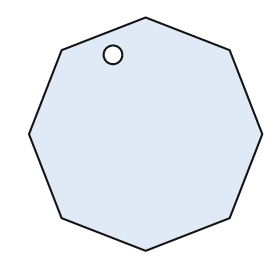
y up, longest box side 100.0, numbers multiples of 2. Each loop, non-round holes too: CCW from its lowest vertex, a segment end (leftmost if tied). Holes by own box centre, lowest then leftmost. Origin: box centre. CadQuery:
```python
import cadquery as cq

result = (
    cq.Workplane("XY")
    .moveTo(0.0, -50.0)
    .lineTo(36.0, -36.0)
    .lineTo(50.0, 0.0)
    .lineTo(36.0, 36.0)
    .lineTo(0.0, 50.0)
    .lineTo(-36.0, 36.0)
    .lineTo(-50.0, 0.0)
    .lineTo(-36.0, -36.0)
    .close()
    .moveTo(-14.0, 34.0)
    .circle(4.0)
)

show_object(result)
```